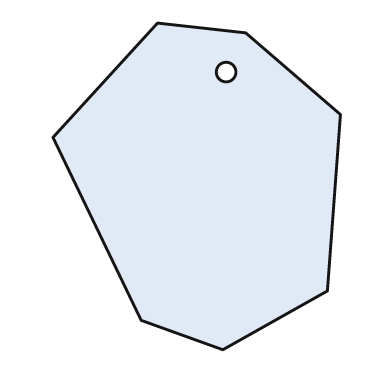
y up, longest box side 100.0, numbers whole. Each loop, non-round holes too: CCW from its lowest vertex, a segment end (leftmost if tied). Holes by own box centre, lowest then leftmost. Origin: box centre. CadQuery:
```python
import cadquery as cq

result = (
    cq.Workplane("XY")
    .moveTo(8.0, -50.0)
    .lineTo(40.0, -32.0)
    .lineTo(44.0, 22.0)
    .lineTo(15.0, 47.0)
    .lineTo(-12.0, 50.0)
    .lineTo(-44.0, 15.0)
    .lineTo(-17.0, -41.0)
    .close()
    .moveTo(9.0, 35.0)
    .circle(3.0)
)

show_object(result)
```